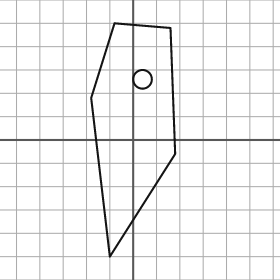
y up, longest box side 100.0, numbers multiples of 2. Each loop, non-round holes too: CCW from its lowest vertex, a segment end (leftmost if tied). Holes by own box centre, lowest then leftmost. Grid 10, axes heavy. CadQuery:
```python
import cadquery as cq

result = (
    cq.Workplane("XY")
    .moveTo(-10.0, -50.0)
    .lineTo(18.0, -6.0)
    .lineTo(16.0, 48.0)
    .lineTo(-8.0, 50.0)
    .lineTo(-18.0, 18.0)
    .close()
    .moveTo(4.0, 26.0)
    .circle(4.0)
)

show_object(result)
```